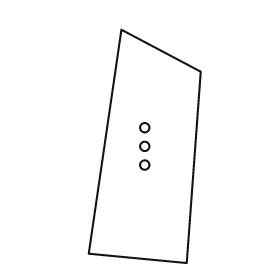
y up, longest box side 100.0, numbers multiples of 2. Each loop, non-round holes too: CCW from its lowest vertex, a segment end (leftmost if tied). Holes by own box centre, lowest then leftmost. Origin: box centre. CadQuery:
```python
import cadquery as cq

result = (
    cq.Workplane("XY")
    .moveTo(18.0, -50.0)
    .lineTo(24.0, 32.0)
    .lineTo(-10.0, 50.0)
    .lineTo(-24.0, -46.0)
    .close()
    .moveTo(0.0, -8.0)
    .circle(2.0)
    .moveTo(0.0, 0.0)
    .circle(2.0)
    .moveTo(0.0, 8.0)
    .circle(2.0)
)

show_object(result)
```